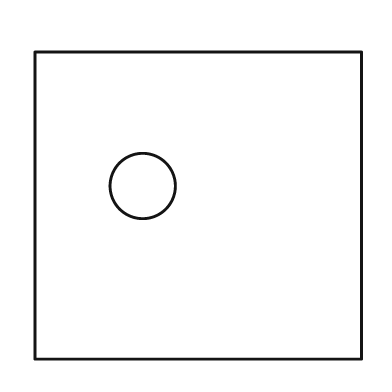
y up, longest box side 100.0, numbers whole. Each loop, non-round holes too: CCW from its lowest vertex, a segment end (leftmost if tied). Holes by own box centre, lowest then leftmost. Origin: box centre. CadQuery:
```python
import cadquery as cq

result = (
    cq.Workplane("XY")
    .moveTo(-50.0, -47.0)
    .lineTo(50.0, -47.0)
    .lineTo(50.0, 47.0)
    .lineTo(-50.0, 47.0)
    .close()
    .moveTo(-17.0, 6.0)
    .circle(10.0)
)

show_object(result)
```